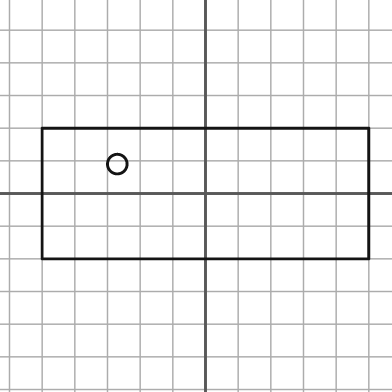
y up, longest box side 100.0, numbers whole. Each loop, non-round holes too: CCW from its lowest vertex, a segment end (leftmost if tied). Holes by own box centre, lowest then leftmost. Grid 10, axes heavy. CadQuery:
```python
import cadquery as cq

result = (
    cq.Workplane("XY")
    .moveTo(-50.0, -20.0)
    .lineTo(50.0, -20.0)
    .lineTo(50.0, 20.0)
    .lineTo(-50.0, 20.0)
    .close()
    .moveTo(-27.0, 9.0)
    .circle(3.0)
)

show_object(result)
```